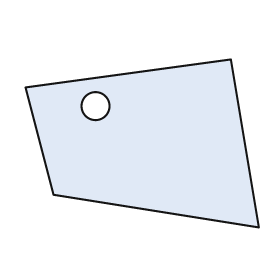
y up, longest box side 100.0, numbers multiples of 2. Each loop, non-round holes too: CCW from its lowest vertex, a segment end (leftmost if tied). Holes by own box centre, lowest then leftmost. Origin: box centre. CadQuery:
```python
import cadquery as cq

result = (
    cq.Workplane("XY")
    .moveTo(50.0, -36.0)
    .lineTo(38.0, 36.0)
    .lineTo(-50.0, 24.0)
    .lineTo(-38.0, -22.0)
    .close()
    .moveTo(-20.0, 16.0)
    .circle(6.0)
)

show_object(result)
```